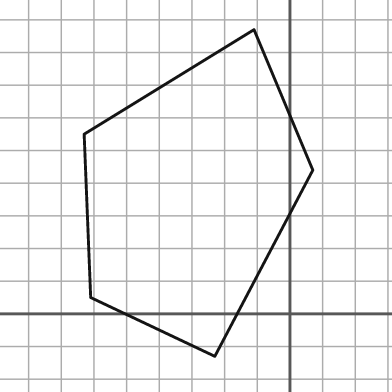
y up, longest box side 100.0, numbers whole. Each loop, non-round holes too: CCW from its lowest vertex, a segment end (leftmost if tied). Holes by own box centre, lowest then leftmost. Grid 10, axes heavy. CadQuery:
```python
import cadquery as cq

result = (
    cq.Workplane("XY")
    .moveTo(-23.0, -13.0)
    .lineTo(7.0, 44.0)
    .lineTo(-11.0, 87.0)
    .lineTo(-63.0, 55.0)
    .lineTo(-61.0, 5.0)
    .close()
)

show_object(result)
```